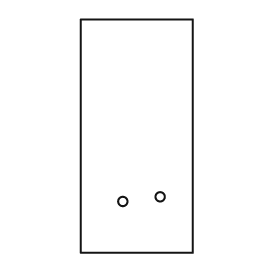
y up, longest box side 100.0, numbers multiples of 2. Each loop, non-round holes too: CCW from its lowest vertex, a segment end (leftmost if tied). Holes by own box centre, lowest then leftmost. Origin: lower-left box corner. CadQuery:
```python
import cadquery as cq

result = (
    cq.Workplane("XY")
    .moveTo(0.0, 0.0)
    .lineTo(48.0, 0.0)
    .lineTo(48.0, 100.0)
    .lineTo(0.0, 100.0)
    .close()
    .moveTo(18.0, 22.0)
    .circle(2.0)
    .moveTo(34.0, 24.0)
    .circle(2.0)
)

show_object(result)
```